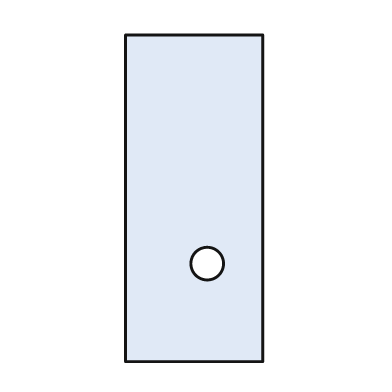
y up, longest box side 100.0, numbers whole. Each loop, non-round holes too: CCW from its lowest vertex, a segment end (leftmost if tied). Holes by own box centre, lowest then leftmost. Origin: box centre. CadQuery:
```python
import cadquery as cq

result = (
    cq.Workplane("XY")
    .moveTo(-21.0, -50.0)
    .lineTo(21.0, -50.0)
    .lineTo(21.0, 50.0)
    .lineTo(-21.0, 50.0)
    .close()
    .moveTo(4.0, -20.0)
    .circle(5.0)
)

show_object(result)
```